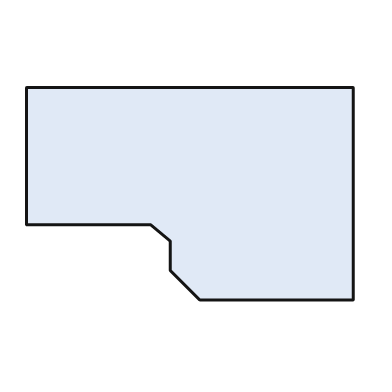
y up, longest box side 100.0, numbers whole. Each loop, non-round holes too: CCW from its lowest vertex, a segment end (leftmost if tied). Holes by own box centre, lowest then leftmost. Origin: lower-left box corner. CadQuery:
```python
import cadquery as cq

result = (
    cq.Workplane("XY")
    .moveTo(53.0, 0.0)
    .lineTo(100.0, 0.0)
    .lineTo(100.0, 65.0)
    .lineTo(0.0, 65.0)
    .lineTo(0.0, 23.0)
    .lineTo(38.0, 23.0)
    .lineTo(44.0, 18.0)
    .lineTo(44.0, 9.0)
    .close()
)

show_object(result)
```